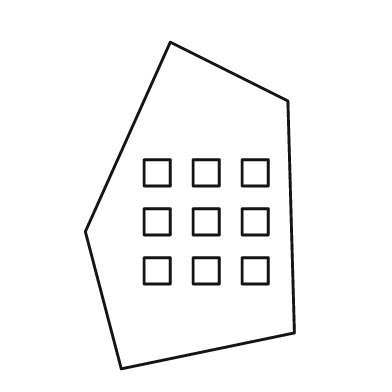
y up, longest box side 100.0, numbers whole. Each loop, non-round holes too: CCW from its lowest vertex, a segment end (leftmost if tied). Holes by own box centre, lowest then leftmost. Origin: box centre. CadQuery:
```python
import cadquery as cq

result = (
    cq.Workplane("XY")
    .moveTo(-21.0, -50.0)
    .lineTo(32.0, -39.0)
    .lineTo(30.0, 32.0)
    .lineTo(-6.0, 50.0)
    .lineTo(-32.0, -8.0)
    .close()
    .moveTo(-14.0, -24.0)
    .lineTo(-6.0, -24.0)
    .lineTo(-6.0, -16.0)
    .lineTo(-14.0, -16.0)
    .close()
    .moveTo(1.0, -24.0)
    .lineTo(9.0, -24.0)
    .lineTo(9.0, -16.0)
    .lineTo(1.0, -16.0)
    .close()
    .moveTo(16.0, -24.0)
    .lineTo(24.0, -24.0)
    .lineTo(24.0, -16.0)
    .lineTo(16.0, -16.0)
    .close()
    .moveTo(-14.0, -9.0)
    .lineTo(-6.0, -9.0)
    .lineTo(-6.0, -1.0)
    .lineTo(-14.0, -1.0)
    .close()
    .moveTo(1.0, -9.0)
    .lineTo(9.0, -9.0)
    .lineTo(9.0, -1.0)
    .lineTo(1.0, -1.0)
    .close()
    .moveTo(16.0, -9.0)
    .lineTo(24.0, -9.0)
    .lineTo(24.0, -1.0)
    .lineTo(16.0, -1.0)
    .close()
    .moveTo(-14.0, 6.0)
    .lineTo(-6.0, 6.0)
    .lineTo(-6.0, 14.0)
    .lineTo(-14.0, 14.0)
    .close()
    .moveTo(1.0, 6.0)
    .lineTo(9.0, 6.0)
    .lineTo(9.0, 14.0)
    .lineTo(1.0, 14.0)
    .close()
    .moveTo(16.0, 6.0)
    .lineTo(24.0, 6.0)
    .lineTo(24.0, 14.0)
    .lineTo(16.0, 14.0)
    .close()
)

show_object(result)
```